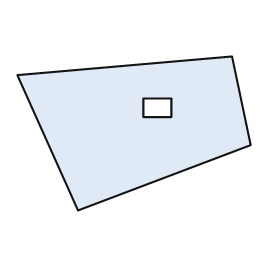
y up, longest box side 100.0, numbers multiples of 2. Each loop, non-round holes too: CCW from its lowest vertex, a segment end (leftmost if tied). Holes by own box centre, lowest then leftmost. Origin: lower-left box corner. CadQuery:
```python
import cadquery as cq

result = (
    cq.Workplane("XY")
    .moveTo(26.0, 0.0)
    .lineTo(100.0, 28.0)
    .lineTo(92.0, 66.0)
    .lineTo(0.0, 58.0)
    .close()
    .moveTo(54.0, 40.0)
    .lineTo(66.0, 40.0)
    .lineTo(66.0, 48.0)
    .lineTo(54.0, 48.0)
    .close()
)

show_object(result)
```